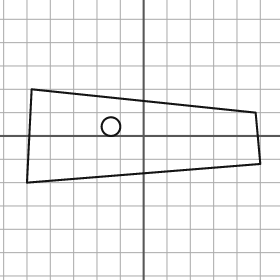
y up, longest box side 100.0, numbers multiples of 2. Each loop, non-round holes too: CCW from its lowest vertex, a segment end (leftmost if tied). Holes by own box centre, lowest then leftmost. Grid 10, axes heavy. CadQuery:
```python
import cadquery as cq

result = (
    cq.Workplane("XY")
    .moveTo(-50.0, -20.0)
    .lineTo(50.0, -12.0)
    .lineTo(48.0, 10.0)
    .lineTo(-48.0, 20.0)
    .close()
    .moveTo(-14.0, 4.0)
    .circle(4.0)
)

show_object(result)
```